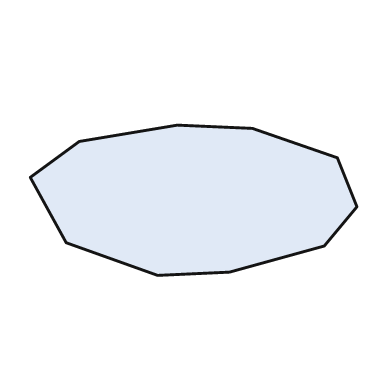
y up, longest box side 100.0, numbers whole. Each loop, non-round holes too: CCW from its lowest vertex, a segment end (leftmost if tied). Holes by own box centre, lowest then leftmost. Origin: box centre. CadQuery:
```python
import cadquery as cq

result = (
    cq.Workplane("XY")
    .moveTo(-11.0, -23.0)
    .lineTo(11.0, -22.0)
    .lineTo(40.0, -14.0)
    .lineTo(50.0, -2.0)
    .lineTo(44.0, 13.0)
    .lineTo(18.0, 22.0)
    .lineTo(-5.0, 23.0)
    .lineTo(-35.0, 18.0)
    .lineTo(-50.0, 7.0)
    .lineTo(-39.0, -13.0)
    .close()
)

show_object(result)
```